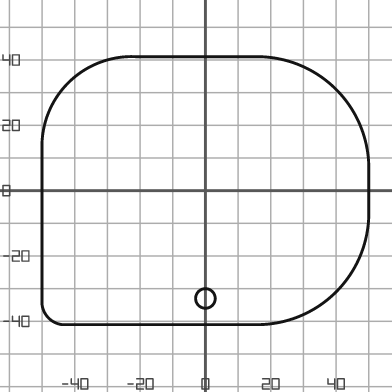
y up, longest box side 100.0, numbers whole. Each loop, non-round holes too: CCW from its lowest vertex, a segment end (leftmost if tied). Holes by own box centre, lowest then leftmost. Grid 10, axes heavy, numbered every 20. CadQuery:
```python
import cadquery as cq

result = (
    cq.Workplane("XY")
    .moveTo(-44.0, -41.0)
    .lineTo(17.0, -41.0)
    .threePointArc((40.0, -31.0), (50.0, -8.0))
    .lineTo(50.0, 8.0)
    .threePointArc((40.0, 31.0), (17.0, 41.0))
    .lineTo(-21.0, 41.0)
    .threePointArc((-42.0, 33.0), (-50.0, 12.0))
    .lineTo(-50.0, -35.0)
    .threePointArc((-48.0, -39.0), (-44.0, -41.0))
    .close()
    .moveTo(0.0, -33.0)
    .circle(3.0)
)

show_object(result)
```